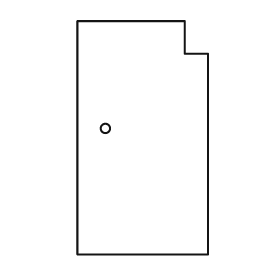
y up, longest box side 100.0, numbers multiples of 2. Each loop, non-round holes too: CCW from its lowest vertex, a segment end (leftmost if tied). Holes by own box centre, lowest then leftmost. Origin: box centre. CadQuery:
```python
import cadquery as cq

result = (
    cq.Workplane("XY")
    .moveTo(-28.0, -50.0)
    .lineTo(28.0, -50.0)
    .lineTo(28.0, 36.0)
    .lineTo(18.0, 36.0)
    .lineTo(18.0, 50.0)
    .lineTo(-28.0, 50.0)
    .close()
    .moveTo(-16.0, 4.0)
    .circle(2.0)
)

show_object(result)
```